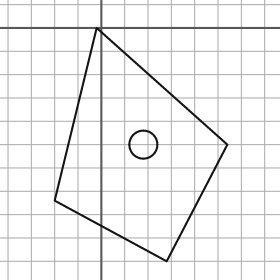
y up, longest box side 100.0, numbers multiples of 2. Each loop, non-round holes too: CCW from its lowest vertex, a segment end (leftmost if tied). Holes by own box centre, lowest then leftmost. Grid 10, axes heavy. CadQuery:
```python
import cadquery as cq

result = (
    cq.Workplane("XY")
    .moveTo(28.0, -100.0)
    .lineTo(54.0, -50.0)
    .lineTo(-2.0, 0.0)
    .lineTo(-20.0, -74.0)
    .close()
    .moveTo(18.0, -50.0)
    .circle(6.0)
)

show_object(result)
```